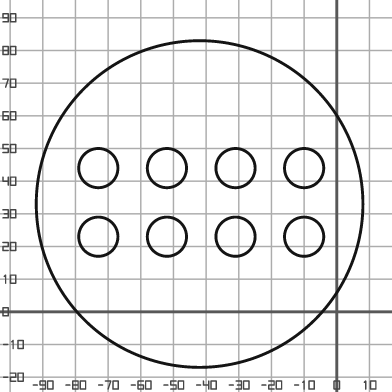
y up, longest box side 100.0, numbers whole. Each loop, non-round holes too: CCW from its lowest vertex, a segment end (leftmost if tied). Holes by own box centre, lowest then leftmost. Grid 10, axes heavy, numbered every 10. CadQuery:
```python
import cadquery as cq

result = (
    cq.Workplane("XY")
    .moveTo(-42.0, 33.0)
    .circle(50.0)
    .moveTo(-73.0, 23.0)
    .circle(6.0)
    .moveTo(-52.0, 23.0)
    .circle(6.0)
    .moveTo(-31.0, 23.0)
    .circle(6.0)
    .moveTo(-10.0, 23.0)
    .circle(6.0)
    .moveTo(-73.0, 44.0)
    .circle(6.0)
    .moveTo(-52.0, 44.0)
    .circle(6.0)
    .moveTo(-31.0, 44.0)
    .circle(6.0)
    .moveTo(-10.0, 44.0)
    .circle(6.0)
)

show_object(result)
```